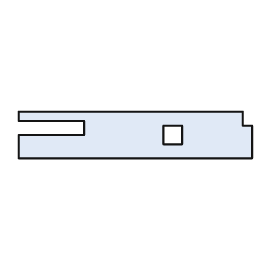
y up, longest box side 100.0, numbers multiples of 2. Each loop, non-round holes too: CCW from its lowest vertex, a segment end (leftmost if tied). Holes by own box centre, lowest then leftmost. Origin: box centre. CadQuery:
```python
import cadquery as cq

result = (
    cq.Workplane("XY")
    .moveTo(-50.0, -10.0)
    .lineTo(50.0, -10.0)
    .lineTo(50.0, 4.0)
    .lineTo(46.0, 4.0)
    .lineTo(46.0, 10.0)
    .lineTo(-50.0, 10.0)
    .lineTo(-50.0, 6.0)
    .lineTo(-22.0, 6.0)
    .lineTo(-22.0, 0.0)
    .lineTo(-50.0, 0.0)
    .close()
    .moveTo(12.0, -4.0)
    .lineTo(20.0, -4.0)
    .lineTo(20.0, 4.0)
    .lineTo(12.0, 4.0)
    .close()
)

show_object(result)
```